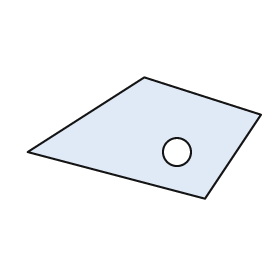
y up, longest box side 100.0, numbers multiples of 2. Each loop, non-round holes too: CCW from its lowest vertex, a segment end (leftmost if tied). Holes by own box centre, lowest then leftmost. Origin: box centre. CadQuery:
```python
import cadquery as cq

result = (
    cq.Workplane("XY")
    .moveTo(26.0, -26.0)
    .lineTo(50.0, 10.0)
    .lineTo(0.0, 26.0)
    .lineTo(-50.0, -6.0)
    .close()
    .moveTo(14.0, -6.0)
    .circle(6.0)
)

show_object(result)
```